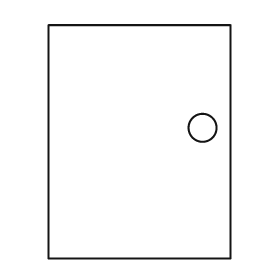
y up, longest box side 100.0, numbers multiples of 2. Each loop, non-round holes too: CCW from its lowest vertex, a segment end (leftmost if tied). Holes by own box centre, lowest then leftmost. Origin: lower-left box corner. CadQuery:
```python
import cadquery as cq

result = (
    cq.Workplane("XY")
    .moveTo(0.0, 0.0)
    .lineTo(78.0, 0.0)
    .lineTo(78.0, 100.0)
    .lineTo(0.0, 100.0)
    .close()
    .moveTo(66.0, 56.0)
    .circle(6.0)
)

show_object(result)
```